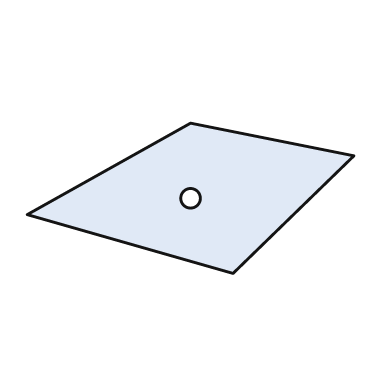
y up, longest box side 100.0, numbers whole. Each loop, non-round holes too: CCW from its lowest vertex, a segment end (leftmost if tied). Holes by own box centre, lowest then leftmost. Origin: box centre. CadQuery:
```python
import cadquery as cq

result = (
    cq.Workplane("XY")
    .moveTo(13.0, -23.0)
    .lineTo(50.0, 13.0)
    .lineTo(0.0, 23.0)
    .lineTo(-50.0, -5.0)
    .close()
    .moveTo(0.0, 0.0)
    .circle(3.0)
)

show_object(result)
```